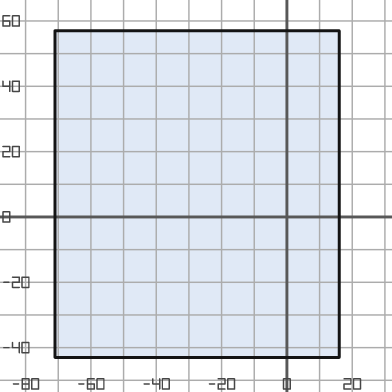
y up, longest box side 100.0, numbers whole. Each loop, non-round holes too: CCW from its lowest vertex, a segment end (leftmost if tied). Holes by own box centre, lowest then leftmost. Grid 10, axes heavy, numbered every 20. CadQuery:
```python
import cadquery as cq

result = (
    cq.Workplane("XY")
    .moveTo(-71.0, -43.0)
    .lineTo(16.0, -43.0)
    .lineTo(16.0, 57.0)
    .lineTo(-71.0, 57.0)
    .close()
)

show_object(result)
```